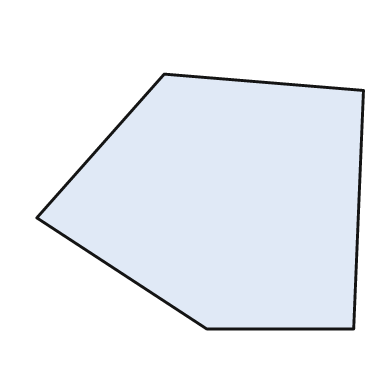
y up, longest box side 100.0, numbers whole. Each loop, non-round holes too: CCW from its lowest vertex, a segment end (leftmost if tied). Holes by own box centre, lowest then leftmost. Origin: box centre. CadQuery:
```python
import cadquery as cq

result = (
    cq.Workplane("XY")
    .moveTo(2.0, -39.0)
    .lineTo(47.0, -39.0)
    .lineTo(50.0, 34.0)
    .lineTo(-11.0, 39.0)
    .lineTo(-50.0, -5.0)
    .close()
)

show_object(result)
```